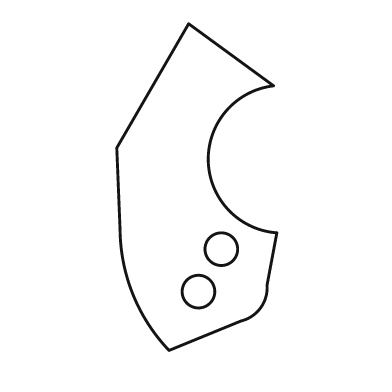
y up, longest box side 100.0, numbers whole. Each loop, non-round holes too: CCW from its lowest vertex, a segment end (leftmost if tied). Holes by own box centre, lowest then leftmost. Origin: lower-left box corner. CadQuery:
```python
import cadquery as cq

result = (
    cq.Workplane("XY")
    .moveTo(16.0, 0.0)
    .lineTo(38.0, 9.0)
    .threePointArc((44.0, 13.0), (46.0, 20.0))
    .lineTo(49.0, 36.0)
    .threePointArc((28.0, 58.0), (48.0, 81.0))
    .lineTo(22.0, 100.0)
    .lineTo(0.0, 62.0)
    .lineTo(1.0, 37.0)
    .threePointArc((5.0, 17.0), (16.0, 0.0))
    .close()
    .moveTo(25.0, 18.0)
    .circle(5.0)
    .moveTo(32.0, 31.0)
    .circle(5.0)
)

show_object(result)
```